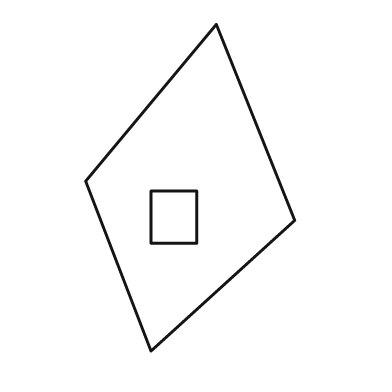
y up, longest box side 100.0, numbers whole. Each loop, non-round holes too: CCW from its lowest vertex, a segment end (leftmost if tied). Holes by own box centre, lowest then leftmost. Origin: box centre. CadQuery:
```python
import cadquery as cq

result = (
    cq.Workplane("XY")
    .moveTo(-12.0, -50.0)
    .lineTo(32.0, -10.0)
    .lineTo(8.0, 50.0)
    .lineTo(-32.0, 2.0)
    .close()
    .moveTo(-12.0, -17.0)
    .lineTo(2.0, -17.0)
    .lineTo(2.0, -1.0)
    .lineTo(-12.0, -1.0)
    .close()
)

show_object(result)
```